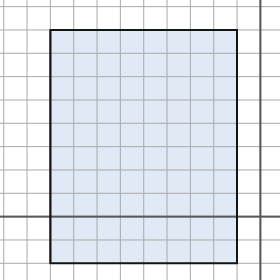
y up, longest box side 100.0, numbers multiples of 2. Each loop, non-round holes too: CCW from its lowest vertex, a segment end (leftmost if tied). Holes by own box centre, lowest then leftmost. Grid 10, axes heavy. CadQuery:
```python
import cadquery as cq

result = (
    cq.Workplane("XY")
    .moveTo(-90.0, -20.0)
    .lineTo(-10.0, -20.0)
    .lineTo(-10.0, 80.0)
    .lineTo(-90.0, 80.0)
    .close()
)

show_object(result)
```